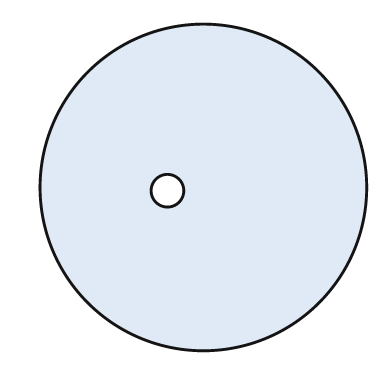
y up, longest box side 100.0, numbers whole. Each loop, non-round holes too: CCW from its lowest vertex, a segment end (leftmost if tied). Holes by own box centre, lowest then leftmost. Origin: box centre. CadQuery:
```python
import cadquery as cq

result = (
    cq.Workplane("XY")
    .moveTo(0.0, 0.0)
    .circle(50.0)
    .moveTo(-11.0, -1.0)
    .circle(5.0)
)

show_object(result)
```